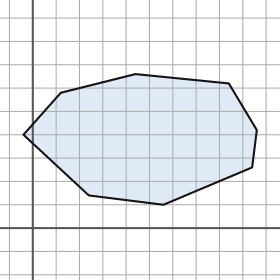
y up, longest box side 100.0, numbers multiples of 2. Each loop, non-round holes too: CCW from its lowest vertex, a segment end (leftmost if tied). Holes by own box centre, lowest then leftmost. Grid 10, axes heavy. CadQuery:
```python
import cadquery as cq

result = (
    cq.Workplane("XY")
    .moveTo(56.0, 10.0)
    .lineTo(94.0, 26.0)
    .lineTo(96.0, 42.0)
    .lineTo(84.0, 62.0)
    .lineTo(44.0, 66.0)
    .lineTo(12.0, 58.0)
    .lineTo(-4.0, 40.0)
    .lineTo(24.0, 14.0)
    .close()
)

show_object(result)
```